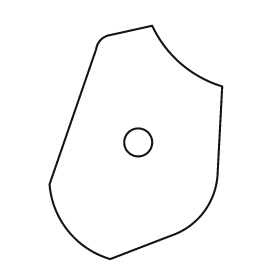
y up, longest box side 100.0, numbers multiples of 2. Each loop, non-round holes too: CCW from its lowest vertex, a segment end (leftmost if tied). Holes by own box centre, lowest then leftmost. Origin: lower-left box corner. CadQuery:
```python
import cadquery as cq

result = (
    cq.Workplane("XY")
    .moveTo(26.0, 0.0)
    .lineTo(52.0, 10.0)
    .threePointArc((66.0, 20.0), (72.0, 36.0))
    .lineTo(74.0, 74.0)
    .threePointArc((56.0, 84.0), (44.0, 100.0))
    .lineTo(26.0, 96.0)
    .threePointArc((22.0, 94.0), (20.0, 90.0))
    .lineTo(0.0, 32.0)
    .threePointArc((8.0, 12.0), (26.0, 0.0))
    .close()
    .moveTo(38.0, 50.0)
    .circle(6.0)
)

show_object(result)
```